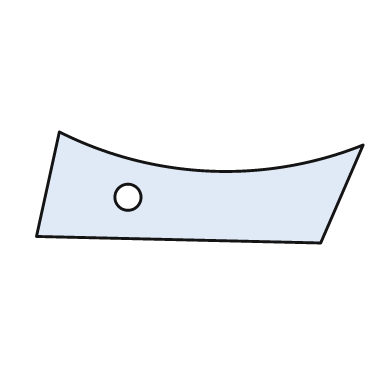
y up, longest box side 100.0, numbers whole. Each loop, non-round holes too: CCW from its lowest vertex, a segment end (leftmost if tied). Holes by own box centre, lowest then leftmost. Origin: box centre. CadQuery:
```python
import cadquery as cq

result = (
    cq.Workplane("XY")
    .moveTo(37.0, -17.0)
    .lineTo(50.0, 13.0)
    .threePointArc((3.0, 5.0), (-43.0, 17.0))
    .lineTo(-50.0, -15.0)
    .close()
    .moveTo(-22.0, -3.0)
    .circle(4.0)
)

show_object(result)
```